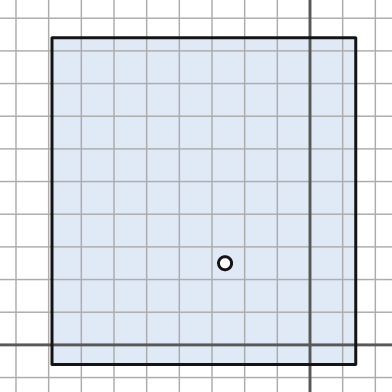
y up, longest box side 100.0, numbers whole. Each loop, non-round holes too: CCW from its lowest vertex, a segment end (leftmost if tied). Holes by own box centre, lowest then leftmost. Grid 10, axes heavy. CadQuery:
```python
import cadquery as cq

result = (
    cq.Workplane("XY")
    .moveTo(-79.0, -6.0)
    .lineTo(14.0, -6.0)
    .lineTo(14.0, 94.0)
    .lineTo(-79.0, 94.0)
    .close()
    .moveTo(-26.0, 25.0)
    .circle(2.0)
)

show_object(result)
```